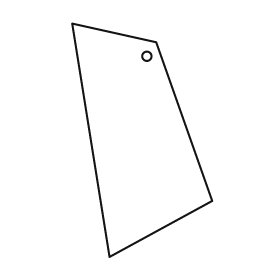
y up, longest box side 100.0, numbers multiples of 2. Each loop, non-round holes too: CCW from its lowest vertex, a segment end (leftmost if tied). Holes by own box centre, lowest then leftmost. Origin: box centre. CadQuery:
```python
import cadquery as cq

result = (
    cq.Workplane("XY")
    .moveTo(-14.0, -50.0)
    .lineTo(30.0, -26.0)
    .lineTo(6.0, 42.0)
    .lineTo(-30.0, 50.0)
    .close()
    .moveTo(2.0, 36.0)
    .circle(2.0)
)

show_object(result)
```